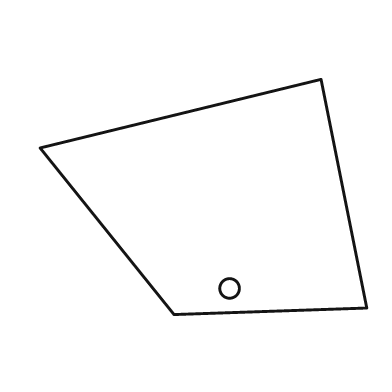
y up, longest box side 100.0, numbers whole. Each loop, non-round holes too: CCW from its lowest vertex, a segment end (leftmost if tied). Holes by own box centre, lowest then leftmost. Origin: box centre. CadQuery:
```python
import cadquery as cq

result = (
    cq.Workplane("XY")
    .moveTo(-9.0, -36.0)
    .lineTo(50.0, -34.0)
    .lineTo(36.0, 36.0)
    .lineTo(-50.0, 15.0)
    .close()
    .moveTo(8.0, -28.0)
    .circle(3.0)
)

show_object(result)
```